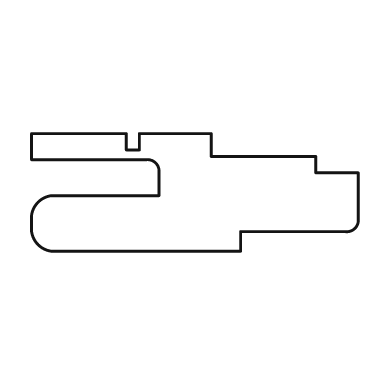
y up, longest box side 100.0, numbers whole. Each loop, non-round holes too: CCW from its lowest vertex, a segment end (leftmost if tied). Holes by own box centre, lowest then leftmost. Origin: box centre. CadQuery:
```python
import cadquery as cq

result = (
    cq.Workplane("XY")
    .moveTo(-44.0, -18.0)
    .lineTo(14.0, -18.0)
    .lineTo(14.0, -12.0)
    .lineTo(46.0, -12.0)
    .threePointArc((49.0, -11.0), (50.0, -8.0))
    .lineTo(50.0, 6.0)
    .lineTo(37.0, 6.0)
    .lineTo(37.0, 11.0)
    .lineTo(5.0, 11.0)
    .lineTo(5.0, 18.0)
    .lineTo(-17.0, 18.0)
    .lineTo(-17.0, 13.0)
    .lineTo(-21.0, 13.0)
    .lineTo(-21.0, 18.0)
    .lineTo(-50.0, 18.0)
    .lineTo(-50.0, 10.0)
    .lineTo(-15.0, 10.0)
    .threePointArc((-12.0, 9.0), (-11.0, 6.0))
    .lineTo(-11.0, -1.0)
    .lineTo(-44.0, -1.0)
    .threePointArc((-48.0, -3.0), (-50.0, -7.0))
    .lineTo(-50.0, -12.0)
    .threePointArc((-48.0, -16.0), (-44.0, -18.0))
    .close()
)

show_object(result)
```